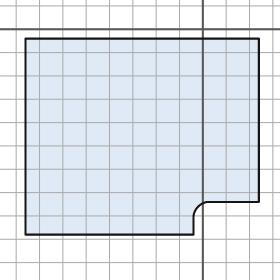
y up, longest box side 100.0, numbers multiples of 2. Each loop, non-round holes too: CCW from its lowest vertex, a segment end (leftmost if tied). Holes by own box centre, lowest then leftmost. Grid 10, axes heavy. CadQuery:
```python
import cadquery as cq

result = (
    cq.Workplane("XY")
    .moveTo(-76.0, -88.0)
    .lineTo(-4.0, -88.0)
    .lineTo(-4.0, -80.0)
    .threePointArc((-2.0, -76.0), (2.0, -74.0))
    .lineTo(24.0, -74.0)
    .lineTo(24.0, -4.0)
    .lineTo(-76.0, -4.0)
    .close()
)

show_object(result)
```